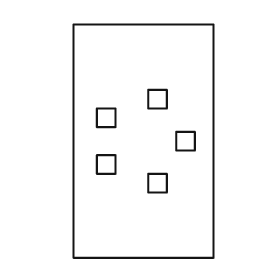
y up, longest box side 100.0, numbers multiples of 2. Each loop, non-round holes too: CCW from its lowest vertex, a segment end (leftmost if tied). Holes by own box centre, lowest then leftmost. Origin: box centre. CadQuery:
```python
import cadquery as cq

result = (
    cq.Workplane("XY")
    .moveTo(-30.0, -50.0)
    .lineTo(30.0, -50.0)
    .lineTo(30.0, 50.0)
    .lineTo(-30.0, 50.0)
    .close()
    .moveTo(2.0, -22.0)
    .lineTo(10.0, -22.0)
    .lineTo(10.0, -14.0)
    .lineTo(2.0, -14.0)
    .close()
    .moveTo(-20.0, -14.0)
    .lineTo(-12.0, -14.0)
    .lineTo(-12.0, -6.0)
    .lineTo(-20.0, -6.0)
    .close()
    .moveTo(14.0, -4.0)
    .lineTo(22.0, -4.0)
    .lineTo(22.0, 4.0)
    .lineTo(14.0, 4.0)
    .close()
    .moveTo(-20.0, 6.0)
    .lineTo(-12.0, 6.0)
    .lineTo(-12.0, 14.0)
    .lineTo(-20.0, 14.0)
    .close()
    .moveTo(2.0, 14.0)
    .lineTo(10.0, 14.0)
    .lineTo(10.0, 22.0)
    .lineTo(2.0, 22.0)
    .close()
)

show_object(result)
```